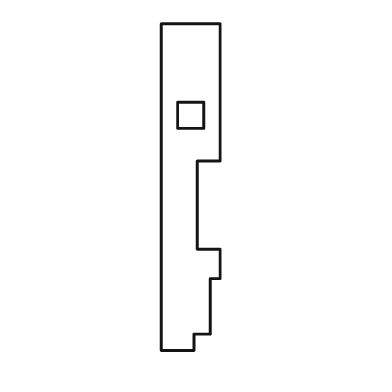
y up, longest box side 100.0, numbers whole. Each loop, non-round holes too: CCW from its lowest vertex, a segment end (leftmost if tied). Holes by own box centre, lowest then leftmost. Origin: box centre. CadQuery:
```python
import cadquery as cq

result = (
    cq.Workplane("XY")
    .moveTo(-9.0, -50.0)
    .lineTo(1.0, -50.0)
    .lineTo(1.0, -45.0)
    .lineTo(6.0, -45.0)
    .lineTo(6.0, -28.0)
    .lineTo(9.0, -28.0)
    .lineTo(9.0, -19.0)
    .lineTo(2.0, -19.0)
    .lineTo(2.0, 8.0)
    .lineTo(9.0, 8.0)
    .lineTo(9.0, 50.0)
    .lineTo(-9.0, 50.0)
    .close()
    .moveTo(-4.0, 18.0)
    .lineTo(4.0, 18.0)
    .lineTo(4.0, 26.0)
    .lineTo(-4.0, 26.0)
    .close()
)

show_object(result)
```